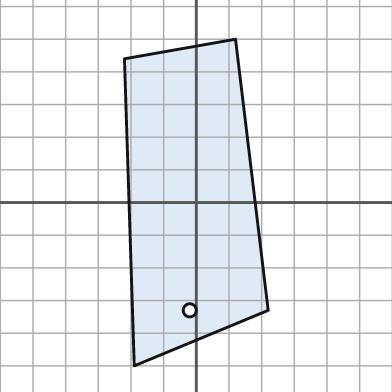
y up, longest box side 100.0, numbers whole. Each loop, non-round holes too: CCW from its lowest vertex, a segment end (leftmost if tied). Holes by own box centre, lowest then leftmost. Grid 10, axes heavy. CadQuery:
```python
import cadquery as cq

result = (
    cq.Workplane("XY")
    .moveTo(-19.0, -50.0)
    .lineTo(22.0, -33.0)
    .lineTo(12.0, 50.0)
    .lineTo(-22.0, 44.0)
    .close()
    .moveTo(-2.0, -33.0)
    .circle(2.0)
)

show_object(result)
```